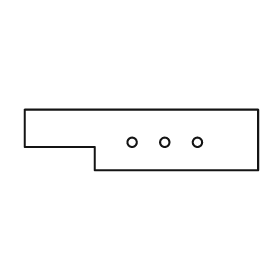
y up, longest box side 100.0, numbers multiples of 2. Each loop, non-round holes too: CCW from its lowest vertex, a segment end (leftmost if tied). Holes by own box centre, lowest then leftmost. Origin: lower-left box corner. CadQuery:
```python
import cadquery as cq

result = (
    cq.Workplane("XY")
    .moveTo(30.0, 0.0)
    .lineTo(100.0, 0.0)
    .lineTo(100.0, 26.0)
    .lineTo(0.0, 26.0)
    .lineTo(0.0, 10.0)
    .lineTo(30.0, 10.0)
    .close()
    .moveTo(46.0, 12.0)
    .circle(2.0)
    .moveTo(60.0, 12.0)
    .circle(2.0)
    .moveTo(74.0, 12.0)
    .circle(2.0)
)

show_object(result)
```